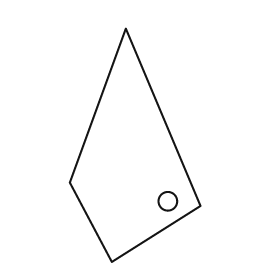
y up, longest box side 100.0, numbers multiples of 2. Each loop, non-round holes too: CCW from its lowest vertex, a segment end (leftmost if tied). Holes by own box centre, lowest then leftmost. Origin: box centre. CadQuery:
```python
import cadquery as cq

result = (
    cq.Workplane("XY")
    .moveTo(-10.0, -50.0)
    .lineTo(28.0, -26.0)
    .lineTo(-4.0, 50.0)
    .lineTo(-28.0, -16.0)
    .close()
    .moveTo(14.0, -24.0)
    .circle(4.0)
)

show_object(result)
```